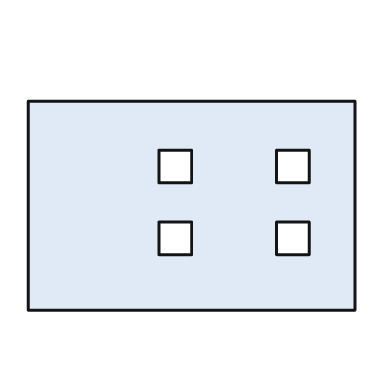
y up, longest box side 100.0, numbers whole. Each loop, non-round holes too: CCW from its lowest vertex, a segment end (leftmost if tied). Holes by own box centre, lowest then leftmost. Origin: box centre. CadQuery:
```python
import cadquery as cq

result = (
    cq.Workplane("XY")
    .moveTo(-50.0, -32.0)
    .lineTo(50.0, -32.0)
    .lineTo(50.0, 32.0)
    .lineTo(-50.0, 32.0)
    .close()
    .moveTo(-10.0, -15.0)
    .lineTo(0.0, -15.0)
    .lineTo(0.0, -5.0)
    .lineTo(-10.0, -5.0)
    .close()
    .moveTo(26.0, -15.0)
    .lineTo(36.0, -15.0)
    .lineTo(36.0, -5.0)
    .lineTo(26.0, -5.0)
    .close()
    .moveTo(-10.0, 7.0)
    .lineTo(0.0, 7.0)
    .lineTo(0.0, 17.0)
    .lineTo(-10.0, 17.0)
    .close()
    .moveTo(26.0, 7.0)
    .lineTo(36.0, 7.0)
    .lineTo(36.0, 17.0)
    .lineTo(26.0, 17.0)
    .close()
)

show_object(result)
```